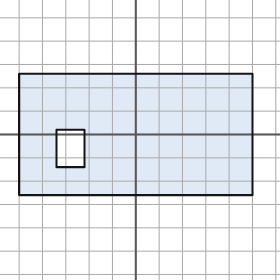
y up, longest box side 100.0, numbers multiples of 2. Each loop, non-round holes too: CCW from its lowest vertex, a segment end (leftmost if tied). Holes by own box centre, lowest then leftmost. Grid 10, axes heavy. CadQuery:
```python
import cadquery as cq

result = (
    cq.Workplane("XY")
    .moveTo(-50.0, -26.0)
    .lineTo(50.0, -26.0)
    .lineTo(50.0, 26.0)
    .lineTo(-50.0, 26.0)
    .close()
    .moveTo(-34.0, -14.0)
    .lineTo(-22.0, -14.0)
    .lineTo(-22.0, 2.0)
    .lineTo(-34.0, 2.0)
    .close()
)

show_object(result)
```